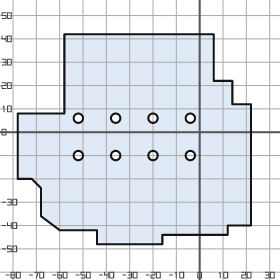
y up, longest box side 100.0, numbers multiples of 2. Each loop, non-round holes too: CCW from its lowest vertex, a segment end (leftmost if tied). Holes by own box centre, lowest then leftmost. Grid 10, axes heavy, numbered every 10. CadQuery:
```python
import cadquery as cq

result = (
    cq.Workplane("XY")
    .moveTo(-44.0, -48.0)
    .lineTo(-16.0, -48.0)
    .lineTo(-16.0, -44.0)
    .lineTo(12.0, -44.0)
    .lineTo(12.0, -40.0)
    .lineTo(22.0, -40.0)
    .lineTo(22.0, 12.0)
    .lineTo(14.0, 12.0)
    .lineTo(14.0, 22.0)
    .lineTo(6.0, 22.0)
    .lineTo(6.0, 42.0)
    .lineTo(-58.0, 42.0)
    .lineTo(-58.0, 8.0)
    .lineTo(-78.0, 8.0)
    .lineTo(-78.0, -20.0)
    .lineTo(-72.0, -20.0)
    .lineTo(-68.0, -24.0)
    .lineTo(-68.0, -36.0)
    .lineTo(-60.0, -42.0)
    .lineTo(-44.0, -42.0)
    .close()
    .moveTo(-52.0, -10.0)
    .circle(2.0)
    .moveTo(-36.0, -10.0)
    .circle(2.0)
    .moveTo(-20.0, -10.0)
    .circle(2.0)
    .moveTo(-4.0, -10.0)
    .circle(2.0)
    .moveTo(-52.0, 6.0)
    .circle(2.0)
    .moveTo(-36.0, 6.0)
    .circle(2.0)
    .moveTo(-20.0, 6.0)
    .circle(2.0)
    .moveTo(-4.0, 6.0)
    .circle(2.0)
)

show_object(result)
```